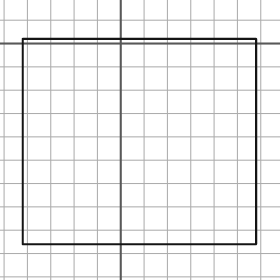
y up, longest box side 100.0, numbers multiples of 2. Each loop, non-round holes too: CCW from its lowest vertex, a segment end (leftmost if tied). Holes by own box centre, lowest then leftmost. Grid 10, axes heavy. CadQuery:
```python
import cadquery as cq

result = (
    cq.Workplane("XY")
    .moveTo(-42.0, -86.0)
    .lineTo(58.0, -86.0)
    .lineTo(58.0, 2.0)
    .lineTo(-42.0, 2.0)
    .close()
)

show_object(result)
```